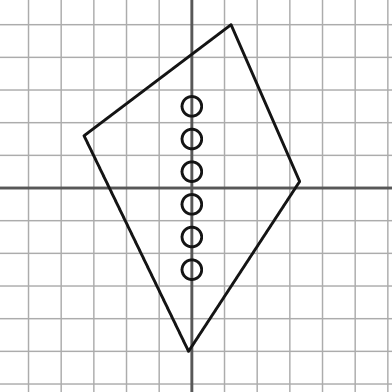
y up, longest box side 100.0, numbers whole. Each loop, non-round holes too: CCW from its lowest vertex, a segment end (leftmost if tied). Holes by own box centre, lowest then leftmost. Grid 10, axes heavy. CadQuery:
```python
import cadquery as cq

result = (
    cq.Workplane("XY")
    .moveTo(-1.0, -50.0)
    .lineTo(33.0, 2.0)
    .lineTo(12.0, 50.0)
    .lineTo(-33.0, 16.0)
    .close()
    .moveTo(0.0, -25.0)
    .circle(3.0)
    .moveTo(0.0, -15.0)
    .circle(3.0)
    .moveTo(0.0, -5.0)
    .circle(3.0)
    .moveTo(0.0, 5.0)
    .circle(3.0)
    .moveTo(0.0, 15.0)
    .circle(3.0)
    .moveTo(0.0, 25.0)
    .circle(3.0)
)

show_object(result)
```